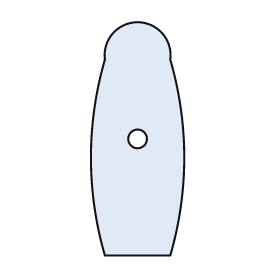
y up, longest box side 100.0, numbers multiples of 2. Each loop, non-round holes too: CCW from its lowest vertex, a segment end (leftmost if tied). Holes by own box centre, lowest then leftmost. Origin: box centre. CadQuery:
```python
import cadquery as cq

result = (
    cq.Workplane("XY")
    .moveTo(-14.0, -50.0)
    .lineTo(14.0, -50.0)
    .threePointArc((20.0, -8.0), (14.0, 34.0))
    .threePointArc((0.0, 50.0), (-14.0, 34.0))
    .threePointArc((-20.0, -8.0), (-14.0, -50.0))
    .close()
    .moveTo(0.0, 0.0)
    .circle(4.0)
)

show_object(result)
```